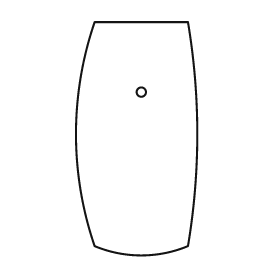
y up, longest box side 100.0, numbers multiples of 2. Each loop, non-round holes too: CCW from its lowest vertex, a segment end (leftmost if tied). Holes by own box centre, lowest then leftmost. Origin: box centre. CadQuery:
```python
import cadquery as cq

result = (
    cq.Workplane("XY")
    .moveTo(-18.0, -46.0)
    .threePointArc((2.0, -50.0), (22.0, -46.0))
    .threePointArc((26.0, 2.0), (22.0, 50.0))
    .lineTo(-18.0, 50.0)
    .threePointArc((-26.0, 2.0), (-18.0, -46.0))
    .close()
    .moveTo(2.0, 20.0)
    .circle(2.0)
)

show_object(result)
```